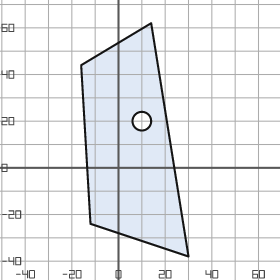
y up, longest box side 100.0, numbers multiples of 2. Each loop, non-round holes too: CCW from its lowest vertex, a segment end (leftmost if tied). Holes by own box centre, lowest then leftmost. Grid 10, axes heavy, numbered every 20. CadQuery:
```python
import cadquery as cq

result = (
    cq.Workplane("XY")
    .moveTo(30.0, -38.0)
    .lineTo(14.0, 62.0)
    .lineTo(-16.0, 44.0)
    .lineTo(-12.0, -24.0)
    .close()
    .moveTo(10.0, 20.0)
    .circle(4.0)
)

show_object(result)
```